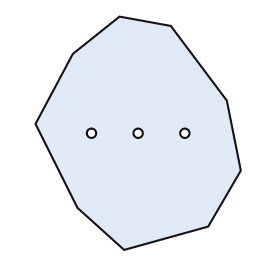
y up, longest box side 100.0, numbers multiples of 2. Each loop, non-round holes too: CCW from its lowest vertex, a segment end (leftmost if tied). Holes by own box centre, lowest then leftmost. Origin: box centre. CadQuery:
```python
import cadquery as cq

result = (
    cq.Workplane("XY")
    .moveTo(-6.0, -50.0)
    .lineTo(30.0, -40.0)
    .lineTo(44.0, -16.0)
    .lineTo(38.0, 14.0)
    .lineTo(14.0, 46.0)
    .lineTo(-8.0, 50.0)
    .lineTo(-28.0, 34.0)
    .lineTo(-44.0, 4.0)
    .lineTo(-26.0, -32.0)
    .close()
    .moveTo(-20.0, 0.0)
    .circle(2.0)
    .moveTo(0.0, 0.0)
    .circle(2.0)
    .moveTo(20.0, 0.0)
    .circle(2.0)
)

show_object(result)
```